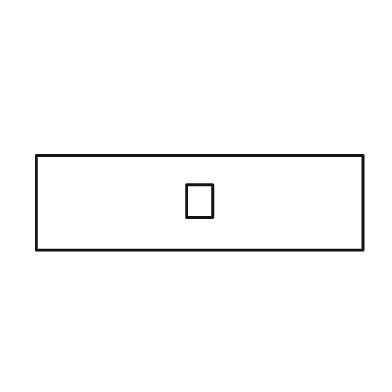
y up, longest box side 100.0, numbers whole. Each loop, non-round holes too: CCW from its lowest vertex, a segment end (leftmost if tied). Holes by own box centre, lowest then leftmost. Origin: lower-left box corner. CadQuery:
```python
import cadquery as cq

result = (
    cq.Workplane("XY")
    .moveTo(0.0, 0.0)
    .lineTo(100.0, 0.0)
    .lineTo(100.0, 29.0)
    .lineTo(0.0, 29.0)
    .close()
    .moveTo(46.0, 10.0)
    .lineTo(54.0, 10.0)
    .lineTo(54.0, 20.0)
    .lineTo(46.0, 20.0)
    .close()
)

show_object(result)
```